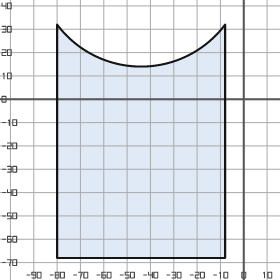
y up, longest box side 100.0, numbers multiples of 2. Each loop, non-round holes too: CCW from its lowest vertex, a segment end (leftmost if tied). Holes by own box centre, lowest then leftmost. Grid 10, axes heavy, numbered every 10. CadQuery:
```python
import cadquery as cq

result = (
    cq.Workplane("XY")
    .moveTo(-80.0, -68.0)
    .lineTo(-8.0, -68.0)
    .lineTo(-8.0, 32.0)
    .threePointArc((-44.0, 14.0), (-80.0, 32.0))
    .close()
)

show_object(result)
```